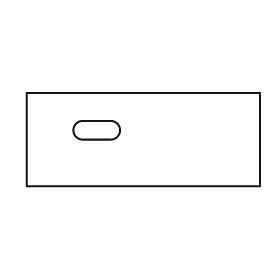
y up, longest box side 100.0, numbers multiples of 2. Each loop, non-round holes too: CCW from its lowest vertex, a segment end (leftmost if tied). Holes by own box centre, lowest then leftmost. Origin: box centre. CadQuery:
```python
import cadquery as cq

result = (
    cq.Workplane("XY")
    .moveTo(-50.0, -20.0)
    .lineTo(50.0, -20.0)
    .lineTo(50.0, 20.0)
    .lineTo(-50.0, 20.0)
    .close()
    .moveTo(-26.0, 0.0)
    .lineTo(-14.0, 0.0)
    .threePointArc((-10.0, 4.0), (-14.0, 8.0))
    .lineTo(-26.0, 8.0)
    .threePointArc((-30.0, 4.0), (-26.0, 0.0))
    .close()
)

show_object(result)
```